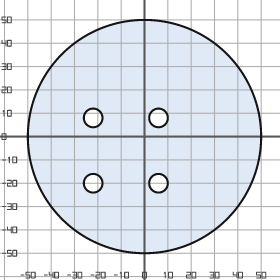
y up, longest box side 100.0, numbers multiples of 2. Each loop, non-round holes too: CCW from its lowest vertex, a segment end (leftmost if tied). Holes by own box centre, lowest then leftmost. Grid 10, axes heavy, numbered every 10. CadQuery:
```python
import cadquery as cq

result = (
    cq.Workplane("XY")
    .moveTo(0.0, 0.0)
    .circle(50.0)
    .moveTo(-22.0, -20.0)
    .circle(4.0)
    .moveTo(6.0, -20.0)
    .circle(4.0)
    .moveTo(-22.0, 8.0)
    .circle(4.0)
    .moveTo(6.0, 8.0)
    .circle(4.0)
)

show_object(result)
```